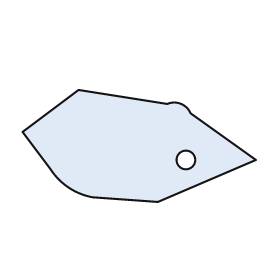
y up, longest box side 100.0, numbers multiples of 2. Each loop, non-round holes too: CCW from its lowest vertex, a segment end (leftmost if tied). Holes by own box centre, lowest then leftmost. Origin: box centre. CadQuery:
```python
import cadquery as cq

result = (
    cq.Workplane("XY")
    .moveTo(8.0, -24.0)
    .lineTo(50.0, -6.0)
    .lineTo(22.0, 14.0)
    .threePointArc((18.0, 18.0), (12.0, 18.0))
    .lineTo(-26.0, 24.0)
    .lineTo(-50.0, 6.0)
    .lineTo(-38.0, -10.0)
    .threePointArc((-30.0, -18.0), (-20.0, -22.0))
    .close()
    .moveTo(20.0, -6.0)
    .circle(4.0)
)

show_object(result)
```